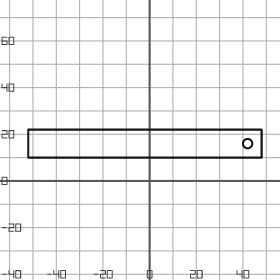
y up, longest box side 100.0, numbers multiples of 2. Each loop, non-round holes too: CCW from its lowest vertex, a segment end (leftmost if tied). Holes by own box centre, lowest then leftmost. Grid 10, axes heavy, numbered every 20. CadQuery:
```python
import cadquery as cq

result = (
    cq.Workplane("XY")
    .moveTo(-52.0, 10.0)
    .lineTo(48.0, 10.0)
    .lineTo(48.0, 22.0)
    .lineTo(-52.0, 22.0)
    .close()
    .moveTo(42.0, 16.0)
    .circle(2.0)
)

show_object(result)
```